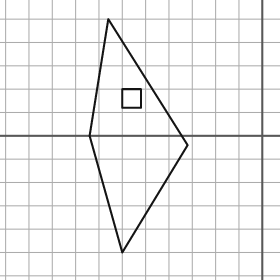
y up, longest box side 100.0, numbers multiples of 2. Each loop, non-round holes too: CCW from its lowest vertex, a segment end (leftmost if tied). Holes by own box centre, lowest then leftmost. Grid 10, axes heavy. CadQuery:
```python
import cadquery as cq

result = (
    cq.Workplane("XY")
    .moveTo(-60.0, -50.0)
    .lineTo(-32.0, -4.0)
    .lineTo(-66.0, 50.0)
    .lineTo(-74.0, 0.0)
    .close()
    .moveTo(-60.0, 12.0)
    .lineTo(-52.0, 12.0)
    .lineTo(-52.0, 20.0)
    .lineTo(-60.0, 20.0)
    .close()
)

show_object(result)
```